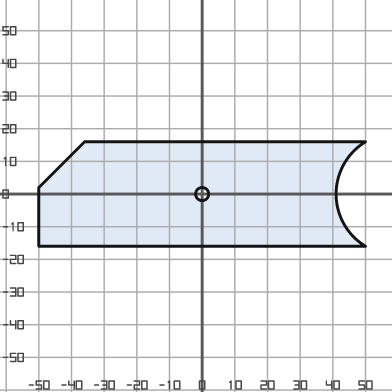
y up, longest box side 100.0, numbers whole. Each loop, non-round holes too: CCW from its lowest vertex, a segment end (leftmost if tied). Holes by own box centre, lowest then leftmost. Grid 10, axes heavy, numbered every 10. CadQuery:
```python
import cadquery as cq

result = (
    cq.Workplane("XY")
    .moveTo(-50.0, -16.0)
    .lineTo(50.0, -16.0)
    .threePointArc((41.0, 0.0), (50.0, 16.0))
    .lineTo(-36.0, 16.0)
    .lineTo(-50.0, 2.0)
    .close()
    .moveTo(0.0, 0.0)
    .circle(2.0)
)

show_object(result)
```